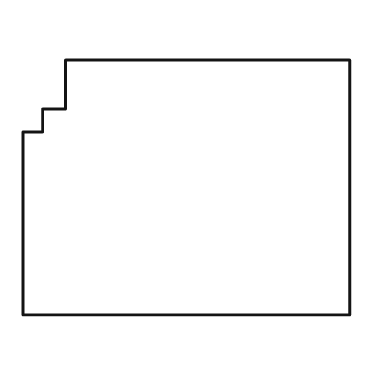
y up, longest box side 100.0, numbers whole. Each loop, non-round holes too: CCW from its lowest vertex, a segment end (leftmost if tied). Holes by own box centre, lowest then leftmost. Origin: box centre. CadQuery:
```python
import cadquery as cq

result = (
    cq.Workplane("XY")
    .moveTo(-50.0, -39.0)
    .lineTo(50.0, -39.0)
    .lineTo(50.0, 39.0)
    .lineTo(-37.0, 39.0)
    .lineTo(-37.0, 24.0)
    .lineTo(-44.0, 24.0)
    .lineTo(-44.0, 17.0)
    .lineTo(-50.0, 17.0)
    .close()
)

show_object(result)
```